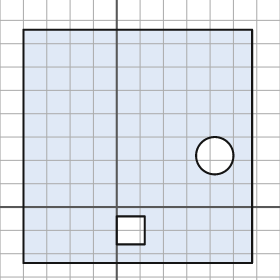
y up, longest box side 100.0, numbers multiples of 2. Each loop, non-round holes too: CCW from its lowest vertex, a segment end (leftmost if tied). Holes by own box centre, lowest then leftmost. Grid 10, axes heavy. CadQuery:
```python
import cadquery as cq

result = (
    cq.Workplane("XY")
    .moveTo(-40.0, -24.0)
    .lineTo(58.0, -24.0)
    .lineTo(58.0, 76.0)
    .lineTo(-40.0, 76.0)
    .close()
    .moveTo(0.0, -16.0)
    .lineTo(12.0, -16.0)
    .lineTo(12.0, -4.0)
    .lineTo(0.0, -4.0)
    .close()
    .moveTo(42.0, 22.0)
    .circle(8.0)
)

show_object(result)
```